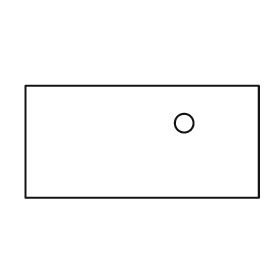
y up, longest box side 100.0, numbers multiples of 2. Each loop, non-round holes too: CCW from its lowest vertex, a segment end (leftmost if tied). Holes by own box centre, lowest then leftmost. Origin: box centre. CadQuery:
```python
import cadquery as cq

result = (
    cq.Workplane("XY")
    .moveTo(-50.0, -24.0)
    .lineTo(50.0, -24.0)
    .lineTo(50.0, 24.0)
    .lineTo(-50.0, 24.0)
    .close()
    .moveTo(18.0, 8.0)
    .circle(4.0)
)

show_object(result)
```